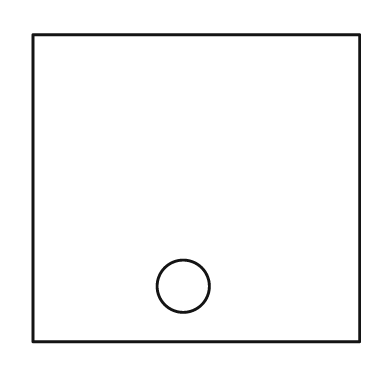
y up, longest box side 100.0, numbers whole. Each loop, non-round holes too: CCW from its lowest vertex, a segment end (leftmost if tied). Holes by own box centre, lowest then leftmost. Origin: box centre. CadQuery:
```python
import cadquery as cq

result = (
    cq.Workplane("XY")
    .moveTo(-50.0, -47.0)
    .lineTo(50.0, -47.0)
    .lineTo(50.0, 47.0)
    .lineTo(-50.0, 47.0)
    .close()
    .moveTo(-4.0, -30.0)
    .circle(8.0)
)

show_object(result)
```